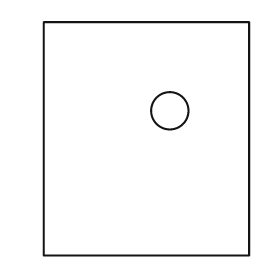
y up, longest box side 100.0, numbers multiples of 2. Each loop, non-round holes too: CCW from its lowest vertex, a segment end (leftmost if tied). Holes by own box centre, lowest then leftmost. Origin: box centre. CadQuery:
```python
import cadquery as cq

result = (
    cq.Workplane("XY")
    .moveTo(-44.0, -50.0)
    .lineTo(44.0, -50.0)
    .lineTo(44.0, 50.0)
    .lineTo(-44.0, 50.0)
    .close()
    .moveTo(10.0, 12.0)
    .circle(8.0)
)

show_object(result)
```